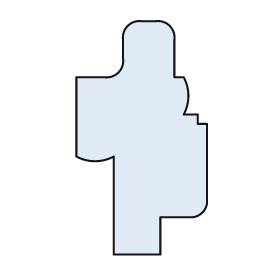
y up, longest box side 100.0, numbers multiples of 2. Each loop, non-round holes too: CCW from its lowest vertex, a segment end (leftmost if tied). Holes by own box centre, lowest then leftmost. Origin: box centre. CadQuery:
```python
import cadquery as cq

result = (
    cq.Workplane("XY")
    .moveTo(-12.0, -50.0)
    .lineTo(8.0, -50.0)
    .lineTo(8.0, -34.0)
    .lineTo(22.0, -34.0)
    .threePointArc((26.0, -32.0), (28.0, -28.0))
    .lineTo(28.0, 6.0)
    .lineTo(24.0, 6.0)
    .lineTo(24.0, 10.0)
    .lineTo(18.0, 10.0)
    .threePointArc((20.0, 18.0), (18.0, 26.0))
    .lineTo(14.0, 26.0)
    .lineTo(14.0, 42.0)
    .threePointArc((12.0, 48.0), (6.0, 50.0))
    .lineTo(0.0, 50.0)
    .threePointArc((-6.0, 48.0), (-8.0, 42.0))
    .lineTo(-8.0, 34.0)
    .threePointArc((-10.0, 28.0), (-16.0, 26.0))
    .lineTo(-28.0, 26.0)
    .lineTo(-28.0, -8.0)
    .threePointArc((-20.0, -10.0), (-12.0, -8.0))
    .close()
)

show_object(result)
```